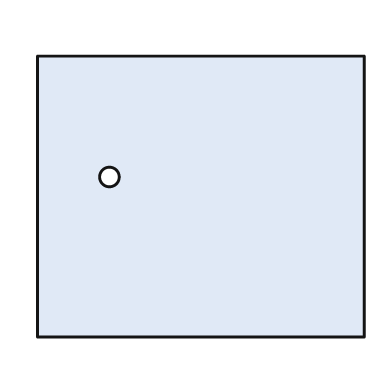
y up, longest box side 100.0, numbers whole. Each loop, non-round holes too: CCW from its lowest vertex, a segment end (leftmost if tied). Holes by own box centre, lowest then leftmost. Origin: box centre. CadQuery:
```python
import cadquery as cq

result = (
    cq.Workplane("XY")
    .moveTo(-50.0, -43.0)
    .lineTo(50.0, -43.0)
    .lineTo(50.0, 43.0)
    .lineTo(-50.0, 43.0)
    .close()
    .moveTo(-28.0, 6.0)
    .circle(3.0)
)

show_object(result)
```